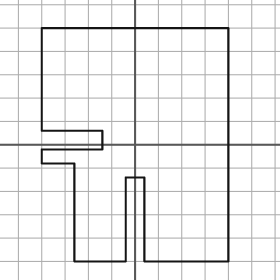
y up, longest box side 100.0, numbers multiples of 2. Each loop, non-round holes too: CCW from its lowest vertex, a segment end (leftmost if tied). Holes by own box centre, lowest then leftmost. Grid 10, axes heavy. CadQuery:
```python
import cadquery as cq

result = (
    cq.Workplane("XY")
    .moveTo(-26.0, -50.0)
    .lineTo(-4.0, -50.0)
    .lineTo(-4.0, -14.0)
    .lineTo(4.0, -14.0)
    .lineTo(4.0, -50.0)
    .lineTo(40.0, -50.0)
    .lineTo(40.0, 50.0)
    .lineTo(-40.0, 50.0)
    .lineTo(-40.0, 6.0)
    .lineTo(-14.0, 6.0)
    .lineTo(-14.0, -2.0)
    .lineTo(-40.0, -2.0)
    .lineTo(-40.0, -8.0)
    .lineTo(-26.0, -8.0)
    .close()
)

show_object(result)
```